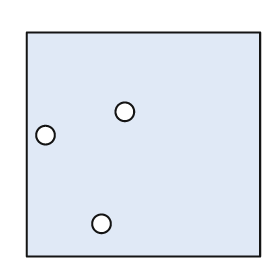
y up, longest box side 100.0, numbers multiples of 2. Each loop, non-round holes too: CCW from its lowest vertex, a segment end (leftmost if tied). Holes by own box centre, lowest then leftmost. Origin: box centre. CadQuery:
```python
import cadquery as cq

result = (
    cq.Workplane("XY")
    .moveTo(-50.0, -48.0)
    .lineTo(50.0, -48.0)
    .lineTo(50.0, 48.0)
    .lineTo(-50.0, 48.0)
    .close()
    .moveTo(-18.0, -34.0)
    .circle(4.0)
    .moveTo(-42.0, 4.0)
    .circle(4.0)
    .moveTo(-8.0, 14.0)
    .circle(4.0)
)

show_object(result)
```